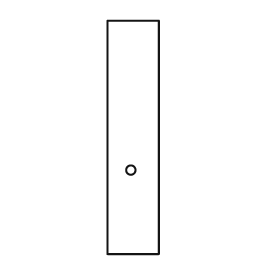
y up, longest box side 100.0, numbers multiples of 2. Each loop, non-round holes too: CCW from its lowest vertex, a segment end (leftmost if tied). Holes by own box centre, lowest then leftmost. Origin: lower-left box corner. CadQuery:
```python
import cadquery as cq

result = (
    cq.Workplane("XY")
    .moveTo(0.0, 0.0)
    .lineTo(22.0, 0.0)
    .lineTo(22.0, 100.0)
    .lineTo(0.0, 100.0)
    .close()
    .moveTo(10.0, 36.0)
    .circle(2.0)
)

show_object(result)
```